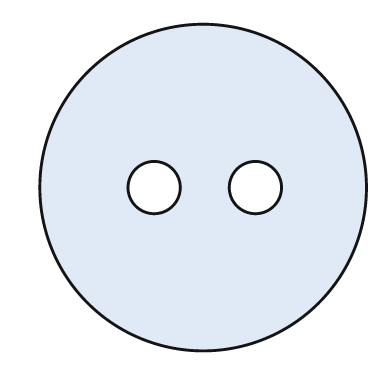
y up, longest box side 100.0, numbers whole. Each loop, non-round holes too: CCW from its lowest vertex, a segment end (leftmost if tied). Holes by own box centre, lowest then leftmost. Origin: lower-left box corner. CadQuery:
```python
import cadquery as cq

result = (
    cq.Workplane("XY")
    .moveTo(50.0, 50.0)
    .circle(50.0)
    .moveTo(35.0, 50.0)
    .circle(8.0)
    .moveTo(66.0, 50.0)
    .circle(8.0)
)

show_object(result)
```